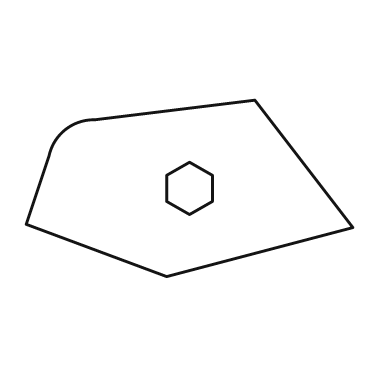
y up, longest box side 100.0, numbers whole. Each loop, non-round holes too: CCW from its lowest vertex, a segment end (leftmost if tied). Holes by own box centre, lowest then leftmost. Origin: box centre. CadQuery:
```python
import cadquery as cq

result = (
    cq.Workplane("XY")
    .moveTo(-7.0, -27.0)
    .lineTo(50.0, -12.0)
    .lineTo(20.0, 27.0)
    .lineTo(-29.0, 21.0)
    .threePointArc((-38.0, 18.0), (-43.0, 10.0))
    .lineTo(-50.0, -11.0)
    .close()
    .moveTo(0.0, -8.0)
    .lineTo(7.0, -4.0)
    .lineTo(7.0, 4.0)
    .lineTo(0.0, 8.0)
    .lineTo(-7.0, 4.0)
    .lineTo(-7.0, -4.0)
    .close()
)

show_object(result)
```